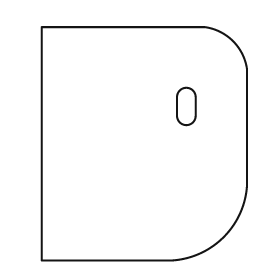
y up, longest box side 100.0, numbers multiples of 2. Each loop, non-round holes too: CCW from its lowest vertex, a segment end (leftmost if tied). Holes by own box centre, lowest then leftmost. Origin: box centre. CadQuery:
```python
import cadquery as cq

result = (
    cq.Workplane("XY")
    .moveTo(-44.0, -50.0)
    .lineTo(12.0, -50.0)
    .threePointArc((34.0, -40.0), (44.0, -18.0))
    .lineTo(44.0, 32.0)
    .threePointArc((38.0, 44.0), (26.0, 50.0))
    .lineTo(-44.0, 50.0)
    .close()
    .moveTo(14.0, 12.0)
    .threePointArc((18.0, 8.0), (22.0, 12.0))
    .lineTo(22.0, 20.0)
    .threePointArc((18.0, 24.0), (14.0, 20.0))
    .close()
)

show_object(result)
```